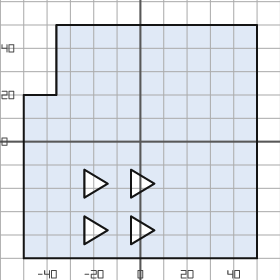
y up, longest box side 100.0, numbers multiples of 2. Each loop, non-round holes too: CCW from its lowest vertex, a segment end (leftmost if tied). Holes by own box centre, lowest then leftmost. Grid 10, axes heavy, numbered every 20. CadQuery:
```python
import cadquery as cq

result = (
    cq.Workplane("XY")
    .moveTo(-50.0, -50.0)
    .lineTo(50.0, -50.0)
    .lineTo(50.0, 50.0)
    .lineTo(-36.0, 50.0)
    .lineTo(-36.0, 20.0)
    .lineTo(-50.0, 20.0)
    .close()
    .moveTo(-24.0, -44.0)
    .lineTo(-14.0, -38.0)
    .lineTo(-24.0, -32.0)
    .close()
    .moveTo(-4.0, -44.0)
    .lineTo(6.0, -38.0)
    .lineTo(-4.0, -32.0)
    .close()
    .moveTo(-24.0, -24.0)
    .lineTo(-14.0, -18.0)
    .lineTo(-24.0, -12.0)
    .close()
    .moveTo(-4.0, -24.0)
    .lineTo(6.0, -18.0)
    .lineTo(-4.0, -12.0)
    .close()
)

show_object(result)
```